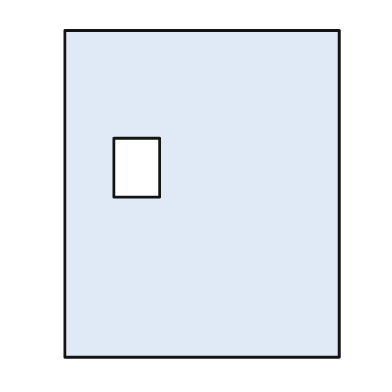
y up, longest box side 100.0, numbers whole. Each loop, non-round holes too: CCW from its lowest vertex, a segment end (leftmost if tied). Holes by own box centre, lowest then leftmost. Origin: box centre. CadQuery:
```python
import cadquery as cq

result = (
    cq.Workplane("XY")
    .moveTo(-42.0, -50.0)
    .lineTo(42.0, -50.0)
    .lineTo(42.0, 50.0)
    .lineTo(-42.0, 50.0)
    .close()
    .moveTo(-27.0, -1.0)
    .lineTo(-13.0, -1.0)
    .lineTo(-13.0, 17.0)
    .lineTo(-27.0, 17.0)
    .close()
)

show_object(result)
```